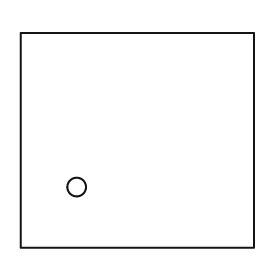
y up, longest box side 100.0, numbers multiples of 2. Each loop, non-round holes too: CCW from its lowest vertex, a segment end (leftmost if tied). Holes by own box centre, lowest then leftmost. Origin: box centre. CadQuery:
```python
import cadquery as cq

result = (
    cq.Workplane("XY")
    .moveTo(-50.0, -46.0)
    .lineTo(50.0, -46.0)
    .lineTo(50.0, 46.0)
    .lineTo(-50.0, 46.0)
    .close()
    .moveTo(-26.0, -20.0)
    .circle(4.0)
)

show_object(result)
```